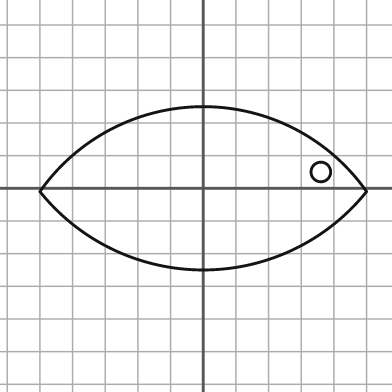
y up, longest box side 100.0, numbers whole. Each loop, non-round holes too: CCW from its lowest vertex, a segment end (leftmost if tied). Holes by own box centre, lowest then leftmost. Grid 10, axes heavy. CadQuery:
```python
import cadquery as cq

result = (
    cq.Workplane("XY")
    .moveTo(-50.0, -1.0)
    .threePointArc((0.0, -25.0), (50.0, -1.0))
    .threePointArc((0.0, 25.0), (-50.0, -1.0))
    .close()
    .moveTo(36.0, 5.0)
    .circle(3.0)
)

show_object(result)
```